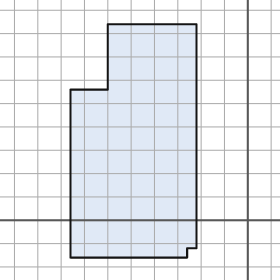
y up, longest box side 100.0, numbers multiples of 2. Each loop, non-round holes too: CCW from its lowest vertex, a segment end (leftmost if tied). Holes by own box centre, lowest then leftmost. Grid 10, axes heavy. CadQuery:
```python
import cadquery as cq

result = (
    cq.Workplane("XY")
    .moveTo(-76.0, -16.0)
    .lineTo(-26.0, -16.0)
    .lineTo(-26.0, -12.0)
    .lineTo(-22.0, -12.0)
    .lineTo(-22.0, 84.0)
    .lineTo(-60.0, 84.0)
    .lineTo(-60.0, 56.0)
    .lineTo(-76.0, 56.0)
    .close()
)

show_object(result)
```